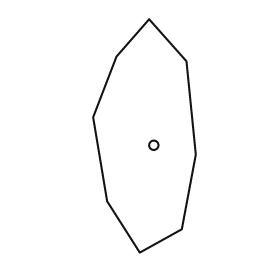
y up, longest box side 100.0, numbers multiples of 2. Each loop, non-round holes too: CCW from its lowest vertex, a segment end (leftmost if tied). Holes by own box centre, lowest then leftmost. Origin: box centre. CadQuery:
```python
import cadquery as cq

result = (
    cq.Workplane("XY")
    .moveTo(-2.0, -50.0)
    .lineTo(16.0, -40.0)
    .lineTo(22.0, -8.0)
    .lineTo(18.0, 32.0)
    .lineTo(2.0, 50.0)
    .lineTo(-12.0, 34.0)
    .lineTo(-22.0, 8.0)
    .lineTo(-16.0, -28.0)
    .close()
    .moveTo(4.0, -4.0)
    .circle(2.0)
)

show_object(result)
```